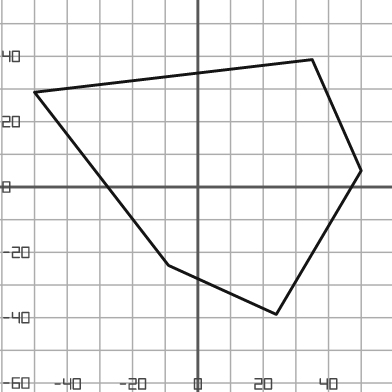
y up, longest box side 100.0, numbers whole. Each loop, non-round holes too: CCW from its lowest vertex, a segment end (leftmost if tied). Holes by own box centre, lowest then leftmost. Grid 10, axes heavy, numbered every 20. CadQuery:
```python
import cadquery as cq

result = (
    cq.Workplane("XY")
    .moveTo(24.0, -39.0)
    .lineTo(50.0, 5.0)
    .lineTo(35.0, 39.0)
    .lineTo(-50.0, 29.0)
    .lineTo(-9.0, -24.0)
    .close()
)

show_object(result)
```